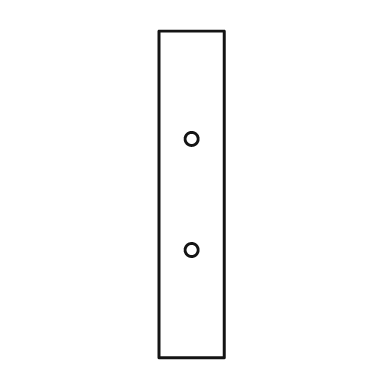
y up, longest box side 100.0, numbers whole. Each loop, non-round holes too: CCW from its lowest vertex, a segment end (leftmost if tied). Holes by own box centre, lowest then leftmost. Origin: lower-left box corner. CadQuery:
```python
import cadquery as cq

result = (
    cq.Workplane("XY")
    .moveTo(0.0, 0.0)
    .lineTo(20.0, 0.0)
    .lineTo(20.0, 100.0)
    .lineTo(0.0, 100.0)
    .close()
    .moveTo(10.0, 33.0)
    .circle(2.0)
    .moveTo(10.0, 67.0)
    .circle(2.0)
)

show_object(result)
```